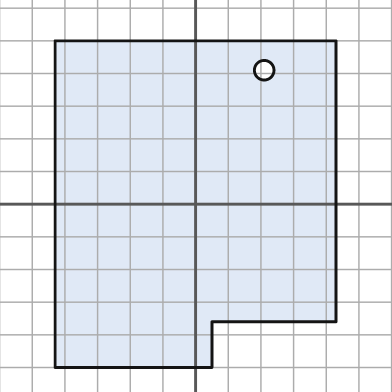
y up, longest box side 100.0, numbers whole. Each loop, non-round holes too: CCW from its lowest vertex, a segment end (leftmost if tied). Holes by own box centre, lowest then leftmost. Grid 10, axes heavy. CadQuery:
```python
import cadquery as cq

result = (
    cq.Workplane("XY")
    .moveTo(-43.0, -50.0)
    .lineTo(5.0, -50.0)
    .lineTo(5.0, -36.0)
    .lineTo(43.0, -36.0)
    .lineTo(43.0, 50.0)
    .lineTo(-43.0, 50.0)
    .close()
    .moveTo(21.0, 41.0)
    .circle(3.0)
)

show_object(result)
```